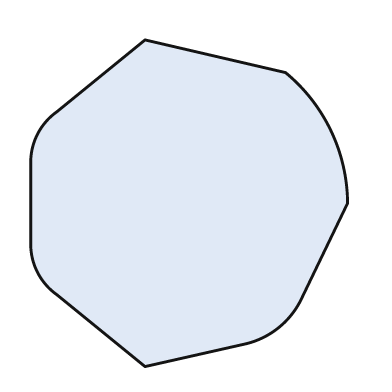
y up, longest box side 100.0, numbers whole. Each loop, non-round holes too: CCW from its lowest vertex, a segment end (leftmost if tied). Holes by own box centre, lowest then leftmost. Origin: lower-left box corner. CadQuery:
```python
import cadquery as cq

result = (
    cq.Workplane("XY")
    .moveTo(35.0, 0.0)
    .lineTo(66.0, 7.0)
    .threePointArc((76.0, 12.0), (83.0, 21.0))
    .lineTo(97.0, 50.0)
    .threePointArc((92.0, 72.0), (78.0, 90.0))
    .lineTo(35.0, 100.0)
    .lineTo(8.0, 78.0)
    .threePointArc((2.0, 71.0), (0.0, 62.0))
    .lineTo(0.0, 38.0)
    .threePointArc((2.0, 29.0), (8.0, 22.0))
    .close()
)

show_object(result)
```